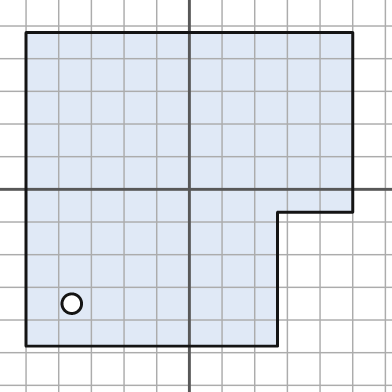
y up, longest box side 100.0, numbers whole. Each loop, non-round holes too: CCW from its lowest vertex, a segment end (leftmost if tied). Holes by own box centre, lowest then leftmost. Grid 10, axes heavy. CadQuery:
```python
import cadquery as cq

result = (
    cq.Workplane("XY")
    .moveTo(-50.0, -48.0)
    .lineTo(27.0, -48.0)
    .lineTo(27.0, -7.0)
    .lineTo(50.0, -7.0)
    .lineTo(50.0, 48.0)
    .lineTo(-50.0, 48.0)
    .close()
    .moveTo(-36.0, -35.0)
    .circle(3.0)
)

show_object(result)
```